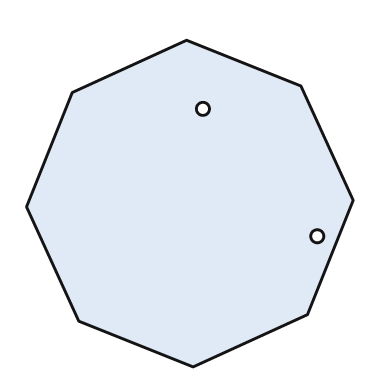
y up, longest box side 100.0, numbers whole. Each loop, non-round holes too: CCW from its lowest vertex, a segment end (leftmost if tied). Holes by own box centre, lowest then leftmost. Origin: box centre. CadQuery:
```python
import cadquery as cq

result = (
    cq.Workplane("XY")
    .moveTo(1.0, -50.0)
    .lineTo(36.0, -34.0)
    .lineTo(50.0, 1.0)
    .lineTo(34.0, 36.0)
    .lineTo(-1.0, 50.0)
    .lineTo(-36.0, 34.0)
    .lineTo(-50.0, -1.0)
    .lineTo(-34.0, -36.0)
    .close()
    .moveTo(39.0, -10.0)
    .circle(2.0)
    .moveTo(4.0, 29.0)
    .circle(2.0)
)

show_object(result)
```